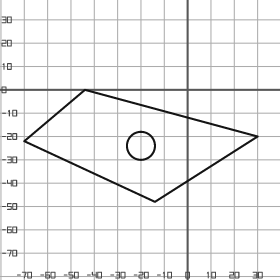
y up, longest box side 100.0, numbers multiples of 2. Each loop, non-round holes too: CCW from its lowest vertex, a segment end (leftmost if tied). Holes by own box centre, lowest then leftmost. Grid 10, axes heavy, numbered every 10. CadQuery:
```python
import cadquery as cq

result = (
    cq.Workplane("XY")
    .moveTo(-14.0, -48.0)
    .lineTo(30.0, -20.0)
    .lineTo(-44.0, 0.0)
    .lineTo(-70.0, -22.0)
    .close()
    .moveTo(-20.0, -24.0)
    .circle(6.0)
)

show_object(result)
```